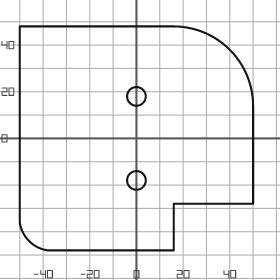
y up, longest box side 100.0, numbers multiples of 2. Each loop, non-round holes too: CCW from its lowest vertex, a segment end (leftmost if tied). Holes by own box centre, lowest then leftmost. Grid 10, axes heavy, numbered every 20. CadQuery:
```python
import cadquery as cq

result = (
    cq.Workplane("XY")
    .moveTo(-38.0, -48.0)
    .lineTo(16.0, -48.0)
    .lineTo(16.0, -28.0)
    .lineTo(50.0, -28.0)
    .lineTo(50.0, 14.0)
    .threePointArc((40.0, 38.0), (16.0, 48.0))
    .lineTo(-50.0, 48.0)
    .lineTo(-50.0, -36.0)
    .threePointArc((-46.0, -44.0), (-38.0, -48.0))
    .close()
    .moveTo(0.0, -18.0)
    .circle(4.0)
    .moveTo(0.0, 18.0)
    .circle(4.0)
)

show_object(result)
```